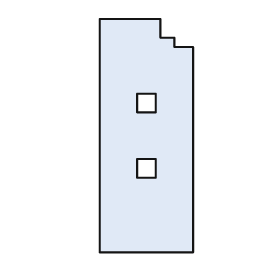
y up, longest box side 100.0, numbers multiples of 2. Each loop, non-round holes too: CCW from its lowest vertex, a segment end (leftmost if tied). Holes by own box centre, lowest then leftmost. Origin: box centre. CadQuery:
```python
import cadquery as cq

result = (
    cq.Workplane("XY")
    .moveTo(-20.0, -50.0)
    .lineTo(20.0, -50.0)
    .lineTo(20.0, 38.0)
    .lineTo(12.0, 38.0)
    .lineTo(12.0, 42.0)
    .lineTo(6.0, 42.0)
    .lineTo(6.0, 50.0)
    .lineTo(-20.0, 50.0)
    .close()
    .moveTo(-4.0, -18.0)
    .lineTo(4.0, -18.0)
    .lineTo(4.0, -10.0)
    .lineTo(-4.0, -10.0)
    .close()
    .moveTo(-4.0, 10.0)
    .lineTo(4.0, 10.0)
    .lineTo(4.0, 18.0)
    .lineTo(-4.0, 18.0)
    .close()
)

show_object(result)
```